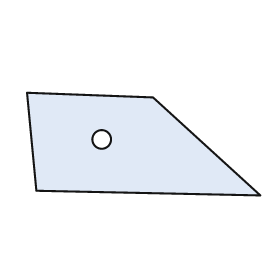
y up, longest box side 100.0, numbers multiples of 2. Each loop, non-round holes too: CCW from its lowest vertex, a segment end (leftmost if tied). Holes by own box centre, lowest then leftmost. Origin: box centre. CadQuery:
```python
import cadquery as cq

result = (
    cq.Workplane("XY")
    .moveTo(50.0, -22.0)
    .lineTo(4.0, 20.0)
    .lineTo(-50.0, 22.0)
    .lineTo(-46.0, -20.0)
    .close()
    .moveTo(-18.0, 2.0)
    .circle(4.0)
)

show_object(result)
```